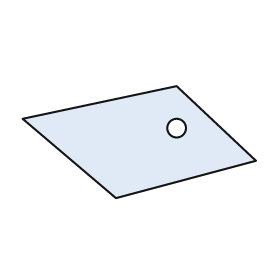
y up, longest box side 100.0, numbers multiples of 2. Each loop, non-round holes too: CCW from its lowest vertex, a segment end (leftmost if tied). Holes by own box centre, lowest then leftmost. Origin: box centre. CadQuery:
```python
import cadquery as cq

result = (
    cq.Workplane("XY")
    .moveTo(-10.0, -24.0)
    .lineTo(50.0, -8.0)
    .lineTo(16.0, 24.0)
    .lineTo(-50.0, 10.0)
    .close()
    .moveTo(16.0, 6.0)
    .circle(4.0)
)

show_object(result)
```